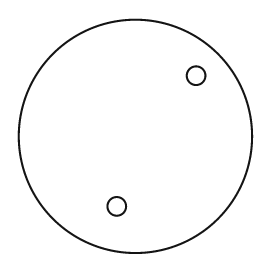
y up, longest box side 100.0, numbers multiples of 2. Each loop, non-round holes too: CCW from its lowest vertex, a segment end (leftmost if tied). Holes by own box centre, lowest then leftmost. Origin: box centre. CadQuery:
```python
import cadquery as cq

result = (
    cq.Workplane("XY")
    .moveTo(0.0, 0.0)
    .circle(50.0)
    .moveTo(-8.0, -30.0)
    .circle(4.0)
    .moveTo(26.0, 26.0)
    .circle(4.0)
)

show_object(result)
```